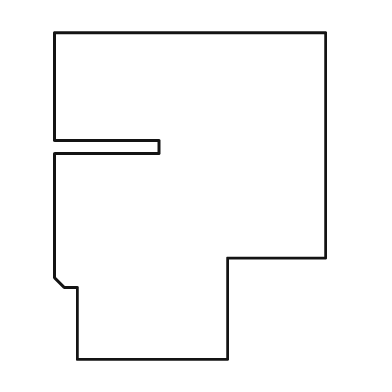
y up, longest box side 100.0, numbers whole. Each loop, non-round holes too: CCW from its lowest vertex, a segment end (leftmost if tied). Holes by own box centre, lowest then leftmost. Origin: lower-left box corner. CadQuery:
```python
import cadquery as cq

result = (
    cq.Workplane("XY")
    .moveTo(7.0, 0.0)
    .lineTo(53.0, 0.0)
    .lineTo(53.0, 31.0)
    .lineTo(83.0, 31.0)
    .lineTo(83.0, 100.0)
    .lineTo(0.0, 100.0)
    .lineTo(0.0, 67.0)
    .lineTo(32.0, 67.0)
    .lineTo(32.0, 63.0)
    .lineTo(0.0, 63.0)
    .lineTo(0.0, 25.0)
    .lineTo(3.0, 22.0)
    .lineTo(7.0, 22.0)
    .close()
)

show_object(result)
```